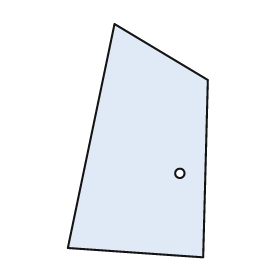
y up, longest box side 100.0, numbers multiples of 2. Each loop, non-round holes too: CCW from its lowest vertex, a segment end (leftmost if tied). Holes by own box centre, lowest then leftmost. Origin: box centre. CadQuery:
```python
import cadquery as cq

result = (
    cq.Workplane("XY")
    .moveTo(28.0, -50.0)
    .lineTo(30.0, 26.0)
    .lineTo(-10.0, 50.0)
    .lineTo(-30.0, -46.0)
    .close()
    .moveTo(18.0, -14.0)
    .circle(2.0)
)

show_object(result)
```